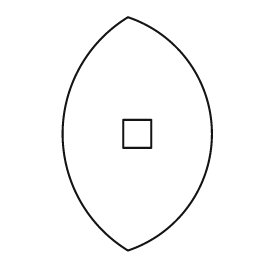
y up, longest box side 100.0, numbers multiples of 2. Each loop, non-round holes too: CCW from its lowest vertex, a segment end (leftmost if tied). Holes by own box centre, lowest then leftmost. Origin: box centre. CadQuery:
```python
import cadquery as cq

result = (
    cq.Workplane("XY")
    .moveTo(-4.0, -50.0)
    .threePointArc((32.0, 0.0), (-4.0, 50.0))
    .threePointArc((-32.0, 0.0), (-4.0, -50.0))
    .close()
    .moveTo(-6.0, -6.0)
    .lineTo(6.0, -6.0)
    .lineTo(6.0, 6.0)
    .lineTo(-6.0, 6.0)
    .close()
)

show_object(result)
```